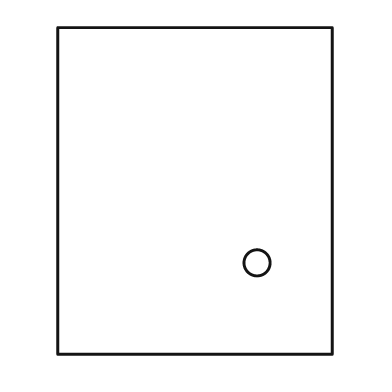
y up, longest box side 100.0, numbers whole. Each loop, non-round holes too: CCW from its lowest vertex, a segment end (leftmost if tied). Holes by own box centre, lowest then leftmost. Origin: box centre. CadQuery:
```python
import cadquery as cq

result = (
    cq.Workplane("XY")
    .moveTo(-42.0, -50.0)
    .lineTo(42.0, -50.0)
    .lineTo(42.0, 50.0)
    .lineTo(-42.0, 50.0)
    .close()
    .moveTo(19.0, -22.0)
    .circle(4.0)
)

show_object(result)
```